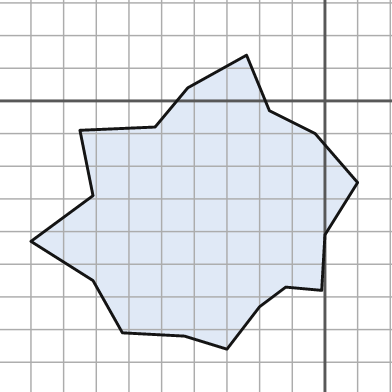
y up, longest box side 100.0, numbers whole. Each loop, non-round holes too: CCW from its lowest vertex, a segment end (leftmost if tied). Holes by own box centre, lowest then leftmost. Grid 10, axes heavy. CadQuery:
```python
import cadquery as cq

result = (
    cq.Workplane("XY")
    .moveTo(-30.0, -76.0)
    .lineTo(-20.0, -63.0)
    .lineTo(-12.0, -57.0)
    .lineTo(-1.0, -58.0)
    .lineTo(0.0, -41.0)
    .lineTo(10.0, -25.0)
    .lineTo(-3.0, -10.0)
    .lineTo(-17.0, -3.0)
    .lineTo(-24.0, 14.0)
    .lineTo(-42.0, 4.0)
    .lineTo(-52.0, -8.0)
    .lineTo(-75.0, -9.0)
    .lineTo(-71.0, -29.0)
    .lineTo(-90.0, -43.0)
    .lineTo(-71.0, -55.0)
    .lineTo(-62.0, -71.0)
    .lineTo(-43.0, -72.0)
    .close()
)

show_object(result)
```